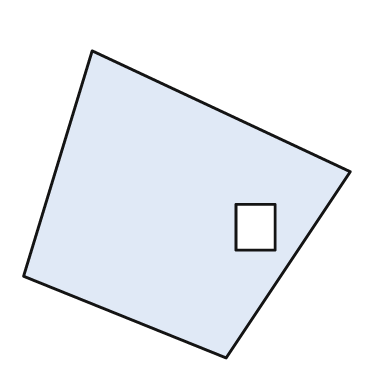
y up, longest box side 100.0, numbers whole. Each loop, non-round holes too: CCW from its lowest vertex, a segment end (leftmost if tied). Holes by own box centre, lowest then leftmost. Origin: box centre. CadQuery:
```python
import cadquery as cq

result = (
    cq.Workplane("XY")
    .moveTo(12.0, -47.0)
    .lineTo(50.0, 10.0)
    .lineTo(-29.0, 47.0)
    .lineTo(-50.0, -22.0)
    .close()
    .moveTo(15.0, -14.0)
    .lineTo(27.0, -14.0)
    .lineTo(27.0, 0.0)
    .lineTo(15.0, 0.0)
    .close()
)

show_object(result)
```